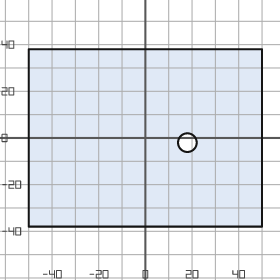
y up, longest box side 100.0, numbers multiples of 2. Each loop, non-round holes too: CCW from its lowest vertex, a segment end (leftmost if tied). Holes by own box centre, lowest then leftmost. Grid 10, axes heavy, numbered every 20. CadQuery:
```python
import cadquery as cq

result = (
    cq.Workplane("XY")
    .moveTo(-50.0, -38.0)
    .lineTo(50.0, -38.0)
    .lineTo(50.0, 38.0)
    .lineTo(-50.0, 38.0)
    .close()
    .moveTo(18.0, -2.0)
    .circle(4.0)
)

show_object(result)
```